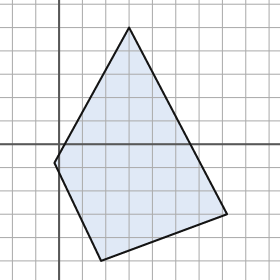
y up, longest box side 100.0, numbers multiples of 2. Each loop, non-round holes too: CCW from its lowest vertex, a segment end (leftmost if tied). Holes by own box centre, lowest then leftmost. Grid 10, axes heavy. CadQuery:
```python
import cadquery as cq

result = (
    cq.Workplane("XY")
    .moveTo(18.0, -50.0)
    .lineTo(72.0, -30.0)
    .lineTo(30.0, 50.0)
    .lineTo(-2.0, -8.0)
    .close()
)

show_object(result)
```